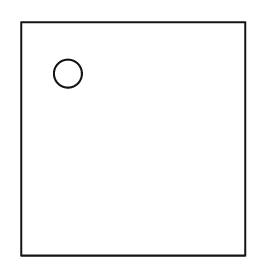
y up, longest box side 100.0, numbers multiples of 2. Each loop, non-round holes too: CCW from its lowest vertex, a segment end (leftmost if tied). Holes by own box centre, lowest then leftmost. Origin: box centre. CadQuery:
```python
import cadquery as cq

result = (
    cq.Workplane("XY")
    .moveTo(-48.0, -50.0)
    .lineTo(48.0, -50.0)
    .lineTo(48.0, 50.0)
    .lineTo(-48.0, 50.0)
    .close()
    .moveTo(-28.0, 28.0)
    .circle(6.0)
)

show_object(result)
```